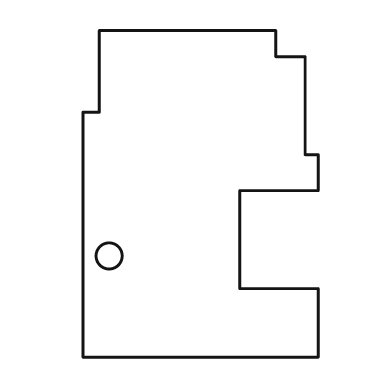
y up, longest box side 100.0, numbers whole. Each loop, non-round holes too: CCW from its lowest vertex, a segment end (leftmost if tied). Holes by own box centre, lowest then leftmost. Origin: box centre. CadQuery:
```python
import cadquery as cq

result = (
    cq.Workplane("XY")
    .moveTo(-36.0, -50.0)
    .lineTo(36.0, -50.0)
    .lineTo(36.0, -29.0)
    .lineTo(12.0, -29.0)
    .lineTo(12.0, 1.0)
    .lineTo(36.0, 1.0)
    .lineTo(36.0, 12.0)
    .lineTo(32.0, 12.0)
    .lineTo(32.0, 42.0)
    .lineTo(23.0, 42.0)
    .lineTo(23.0, 50.0)
    .lineTo(-31.0, 50.0)
    .lineTo(-31.0, 25.0)
    .lineTo(-36.0, 25.0)
    .close()
    .moveTo(-28.0, -19.0)
    .circle(4.0)
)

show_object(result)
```